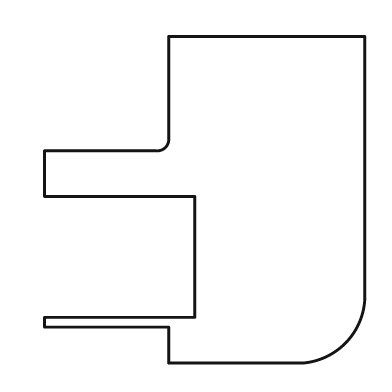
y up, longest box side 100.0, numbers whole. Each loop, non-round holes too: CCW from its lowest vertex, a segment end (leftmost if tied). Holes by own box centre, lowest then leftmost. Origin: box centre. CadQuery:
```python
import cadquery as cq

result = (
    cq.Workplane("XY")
    .moveTo(-11.0, -50.0)
    .lineTo(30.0, -50.0)
    .threePointArc((43.0, -44.0), (49.0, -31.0))
    .lineTo(49.0, 50.0)
    .lineTo(-11.0, 50.0)
    .lineTo(-11.0, 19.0)
    .threePointArc((-12.0, 16.0), (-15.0, 15.0))
    .lineTo(-49.0, 15.0)
    .lineTo(-49.0, 1.0)
    .lineTo(-3.0, 1.0)
    .lineTo(-3.0, -36.0)
    .lineTo(-49.0, -36.0)
    .lineTo(-49.0, -39.0)
    .lineTo(-11.0, -39.0)
    .close()
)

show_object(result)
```